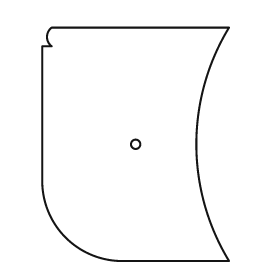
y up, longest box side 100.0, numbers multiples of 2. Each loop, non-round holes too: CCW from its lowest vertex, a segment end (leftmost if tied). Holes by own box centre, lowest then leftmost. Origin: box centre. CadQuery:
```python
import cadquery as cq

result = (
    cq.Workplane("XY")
    .moveTo(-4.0, -50.0)
    .lineTo(40.0, -50.0)
    .threePointArc((26.0, 0.0), (40.0, 50.0))
    .lineTo(-36.0, 50.0)
    .threePointArc((-38.0, 46.0), (-36.0, 42.0))
    .lineTo(-40.0, 42.0)
    .lineTo(-40.0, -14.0)
    .threePointArc((-30.0, -40.0), (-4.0, -50.0))
    .close()
    .moveTo(0.0, 0.0)
    .circle(2.0)
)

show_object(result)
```